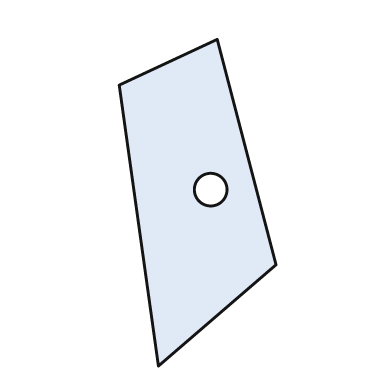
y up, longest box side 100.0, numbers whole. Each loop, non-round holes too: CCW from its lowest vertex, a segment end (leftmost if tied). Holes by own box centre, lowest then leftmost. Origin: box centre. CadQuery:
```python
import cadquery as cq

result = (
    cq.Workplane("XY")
    .moveTo(-12.0, -50.0)
    .lineTo(24.0, -19.0)
    .lineTo(6.0, 50.0)
    .lineTo(-24.0, 36.0)
    .close()
    .moveTo(4.0, 4.0)
    .circle(5.0)
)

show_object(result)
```